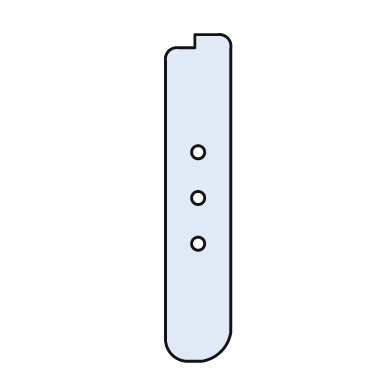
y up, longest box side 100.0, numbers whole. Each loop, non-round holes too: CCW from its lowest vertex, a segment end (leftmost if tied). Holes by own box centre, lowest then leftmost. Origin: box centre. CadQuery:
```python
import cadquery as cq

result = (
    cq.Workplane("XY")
    .moveTo(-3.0, -50.0)
    .lineTo(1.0, -50.0)
    .threePointArc((7.0, -47.0), (10.0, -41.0))
    .lineTo(10.0, 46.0)
    .threePointArc((9.0, 49.0), (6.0, 50.0))
    .lineTo(-1.0, 50.0)
    .lineTo(-1.0, 46.0)
    .lineTo(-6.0, 46.0)
    .threePointArc((-9.0, 45.0), (-10.0, 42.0))
    .lineTo(-10.0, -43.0)
    .threePointArc((-8.0, -48.0), (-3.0, -50.0))
    .close()
    .moveTo(0.0, -14.0)
    .circle(2.0)
    .moveTo(0.0, 0.0)
    .circle(2.0)
    .moveTo(0.0, 14.0)
    .circle(2.0)
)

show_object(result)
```